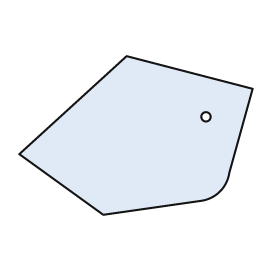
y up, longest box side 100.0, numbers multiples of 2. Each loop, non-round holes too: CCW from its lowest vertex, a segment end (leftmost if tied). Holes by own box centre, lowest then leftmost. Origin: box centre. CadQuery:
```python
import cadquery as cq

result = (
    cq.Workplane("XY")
    .moveTo(-14.0, -34.0)
    .lineTo(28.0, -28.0)
    .threePointArc((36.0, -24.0), (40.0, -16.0))
    .lineTo(50.0, 20.0)
    .lineTo(-4.0, 34.0)
    .lineTo(-50.0, -8.0)
    .close()
    .moveTo(30.0, 8.0)
    .circle(2.0)
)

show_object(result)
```